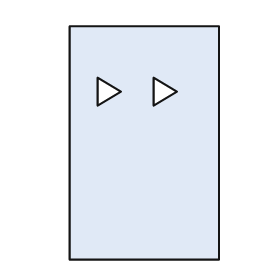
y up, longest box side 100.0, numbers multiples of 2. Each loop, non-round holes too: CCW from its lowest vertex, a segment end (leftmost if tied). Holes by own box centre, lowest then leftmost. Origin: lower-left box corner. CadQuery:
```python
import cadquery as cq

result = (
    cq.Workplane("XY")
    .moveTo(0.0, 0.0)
    .lineTo(64.0, 0.0)
    .lineTo(64.0, 100.0)
    .lineTo(0.0, 100.0)
    .close()
    .moveTo(12.0, 66.0)
    .lineTo(22.0, 72.0)
    .lineTo(12.0, 78.0)
    .close()
    .moveTo(36.0, 66.0)
    .lineTo(46.0, 72.0)
    .lineTo(36.0, 78.0)
    .close()
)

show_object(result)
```